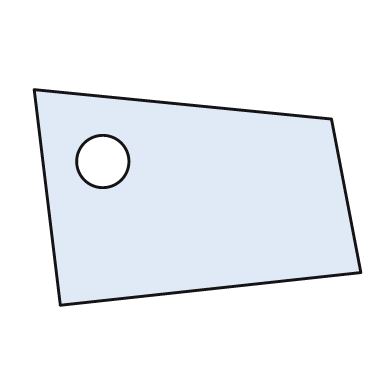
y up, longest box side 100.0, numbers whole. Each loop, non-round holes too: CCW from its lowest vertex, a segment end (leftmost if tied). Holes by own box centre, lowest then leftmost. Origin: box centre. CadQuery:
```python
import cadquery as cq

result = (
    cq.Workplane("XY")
    .moveTo(-42.0, -33.0)
    .lineTo(50.0, -23.0)
    .lineTo(41.0, 24.0)
    .lineTo(-50.0, 33.0)
    .close()
    .moveTo(-29.0, 11.0)
    .circle(8.0)
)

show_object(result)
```